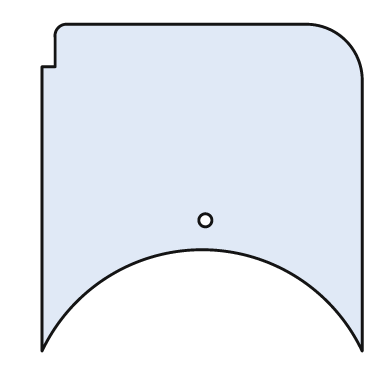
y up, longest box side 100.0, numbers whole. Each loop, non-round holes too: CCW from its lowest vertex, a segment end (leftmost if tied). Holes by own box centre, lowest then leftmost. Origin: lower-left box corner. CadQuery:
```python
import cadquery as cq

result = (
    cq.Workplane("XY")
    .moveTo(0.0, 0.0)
    .threePointArc((49.0, 31.0), (98.0, 0.0))
    .lineTo(98.0, 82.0)
    .threePointArc((93.0, 95.0), (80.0, 100.0))
    .lineTo(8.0, 100.0)
    .threePointArc((5.0, 99.0), (4.0, 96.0))
    .lineTo(4.0, 87.0)
    .lineTo(0.0, 87.0)
    .close()
    .moveTo(50.0, 40.0)
    .circle(2.0)
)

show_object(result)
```